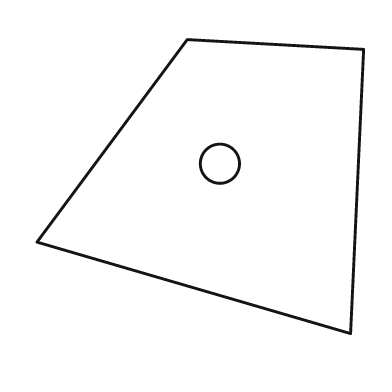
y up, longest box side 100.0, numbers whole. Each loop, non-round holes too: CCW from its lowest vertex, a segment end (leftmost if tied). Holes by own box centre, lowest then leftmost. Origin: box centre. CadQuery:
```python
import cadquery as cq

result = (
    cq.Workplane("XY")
    .moveTo(46.0, -45.0)
    .lineTo(50.0, 42.0)
    .lineTo(-4.0, 45.0)
    .lineTo(-50.0, -17.0)
    .close()
    .moveTo(6.0, 7.0)
    .circle(6.0)
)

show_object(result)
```